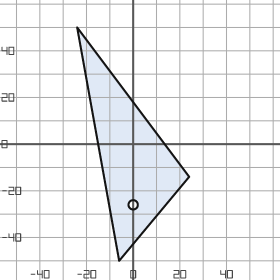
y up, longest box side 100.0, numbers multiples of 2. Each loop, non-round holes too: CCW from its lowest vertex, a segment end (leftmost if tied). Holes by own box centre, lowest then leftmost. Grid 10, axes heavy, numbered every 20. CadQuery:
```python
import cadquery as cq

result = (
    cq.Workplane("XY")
    .moveTo(-6.0, -50.0)
    .lineTo(24.0, -14.0)
    .lineTo(-24.0, 50.0)
    .close()
    .moveTo(0.0, -26.0)
    .circle(2.0)
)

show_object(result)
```